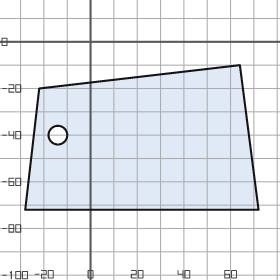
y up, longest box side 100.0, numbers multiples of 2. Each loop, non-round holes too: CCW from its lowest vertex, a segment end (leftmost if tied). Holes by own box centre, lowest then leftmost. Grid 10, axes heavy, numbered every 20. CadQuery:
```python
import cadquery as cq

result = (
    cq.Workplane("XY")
    .moveTo(-28.0, -72.0)
    .lineTo(72.0, -72.0)
    .lineTo(64.0, -10.0)
    .lineTo(-22.0, -20.0)
    .close()
    .moveTo(-14.0, -40.0)
    .circle(4.0)
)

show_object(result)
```